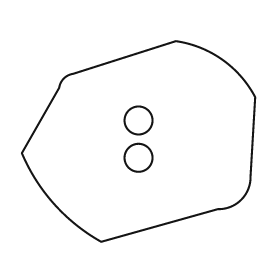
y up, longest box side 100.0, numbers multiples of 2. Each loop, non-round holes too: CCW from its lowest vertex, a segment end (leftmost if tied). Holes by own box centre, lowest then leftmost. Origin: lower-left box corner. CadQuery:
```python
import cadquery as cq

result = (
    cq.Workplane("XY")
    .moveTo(34.0, 0.0)
    .lineTo(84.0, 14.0)
    .threePointArc((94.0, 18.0), (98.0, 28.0))
    .lineTo(100.0, 62.0)
    .threePointArc((86.0, 78.0), (66.0, 86.0))
    .lineTo(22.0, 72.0)
    .threePointArc((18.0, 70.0), (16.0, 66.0))
    .lineTo(0.0, 38.0)
    .threePointArc((14.0, 16.0), (34.0, 0.0))
    .close()
    .moveTo(50.0, 36.0)
    .circle(6.0)
    .moveTo(50.0, 52.0)
    .circle(6.0)
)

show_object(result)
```